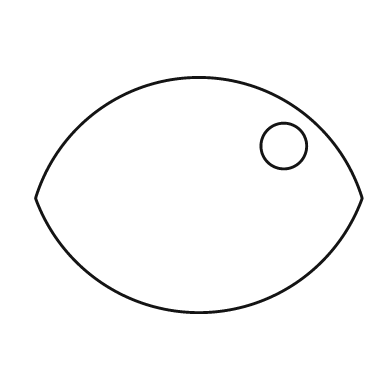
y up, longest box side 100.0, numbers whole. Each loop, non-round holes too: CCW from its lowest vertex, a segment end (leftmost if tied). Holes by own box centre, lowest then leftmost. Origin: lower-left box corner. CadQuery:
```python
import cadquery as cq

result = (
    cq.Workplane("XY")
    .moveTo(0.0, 35.0)
    .threePointArc((50.0, 0.0), (100.0, 35.0))
    .threePointArc((50.0, 72.0), (0.0, 35.0))
    .close()
    .moveTo(76.0, 51.0)
    .circle(7.0)
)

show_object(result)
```